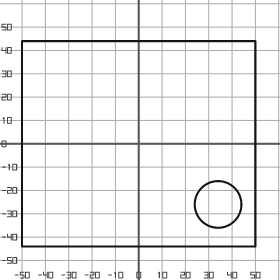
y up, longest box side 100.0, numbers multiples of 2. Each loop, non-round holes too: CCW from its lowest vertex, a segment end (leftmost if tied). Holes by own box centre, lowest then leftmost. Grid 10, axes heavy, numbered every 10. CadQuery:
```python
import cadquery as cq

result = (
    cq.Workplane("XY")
    .moveTo(-50.0, -44.0)
    .lineTo(50.0, -44.0)
    .lineTo(50.0, 44.0)
    .lineTo(-50.0, 44.0)
    .close()
    .moveTo(34.0, -26.0)
    .circle(10.0)
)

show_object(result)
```